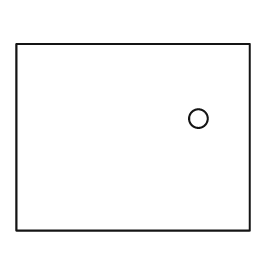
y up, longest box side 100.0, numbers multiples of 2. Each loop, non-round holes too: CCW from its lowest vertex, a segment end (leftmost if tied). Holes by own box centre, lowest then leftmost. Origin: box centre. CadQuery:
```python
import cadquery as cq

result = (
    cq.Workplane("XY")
    .moveTo(-50.0, -40.0)
    .lineTo(50.0, -40.0)
    .lineTo(50.0, 40.0)
    .lineTo(-50.0, 40.0)
    .close()
    .moveTo(28.0, 8.0)
    .circle(4.0)
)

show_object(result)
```